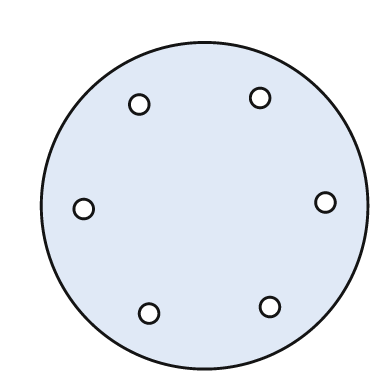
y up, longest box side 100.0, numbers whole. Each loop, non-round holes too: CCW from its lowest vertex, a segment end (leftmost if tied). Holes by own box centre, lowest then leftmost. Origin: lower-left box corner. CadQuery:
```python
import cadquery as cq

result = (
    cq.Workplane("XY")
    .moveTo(50.0, 50.0)
    .circle(50.0)
    .moveTo(33.0, 17.0)
    .circle(3.0)
    .moveTo(70.0, 19.0)
    .circle(3.0)
    .moveTo(13.0, 49.0)
    .circle(3.0)
    .moveTo(87.0, 51.0)
    .circle(3.0)
    .moveTo(30.0, 81.0)
    .circle(3.0)
    .moveTo(67.0, 83.0)
    .circle(3.0)
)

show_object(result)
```